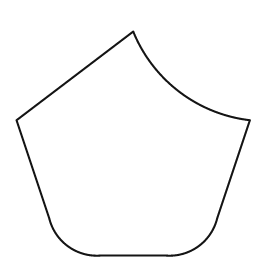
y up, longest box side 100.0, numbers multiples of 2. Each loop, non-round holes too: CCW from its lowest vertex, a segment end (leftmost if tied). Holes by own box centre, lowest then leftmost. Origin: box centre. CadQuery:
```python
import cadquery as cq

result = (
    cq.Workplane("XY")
    .moveTo(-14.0, -48.0)
    .lineTo(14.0, -48.0)
    .threePointArc((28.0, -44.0), (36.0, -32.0))
    .lineTo(50.0, 10.0)
    .threePointArc((20.0, 22.0), (0.0, 48.0))
    .lineTo(-50.0, 10.0)
    .lineTo(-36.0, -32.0)
    .threePointArc((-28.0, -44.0), (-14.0, -48.0))
    .close()
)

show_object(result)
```